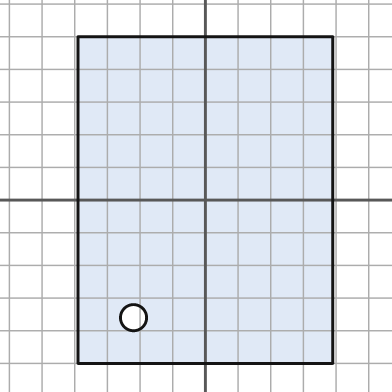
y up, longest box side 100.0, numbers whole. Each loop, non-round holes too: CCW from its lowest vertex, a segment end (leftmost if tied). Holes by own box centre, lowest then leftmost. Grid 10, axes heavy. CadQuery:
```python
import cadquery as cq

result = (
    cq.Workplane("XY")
    .moveTo(-39.0, -50.0)
    .lineTo(39.0, -50.0)
    .lineTo(39.0, 50.0)
    .lineTo(-39.0, 50.0)
    .close()
    .moveTo(-22.0, -36.0)
    .circle(4.0)
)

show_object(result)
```